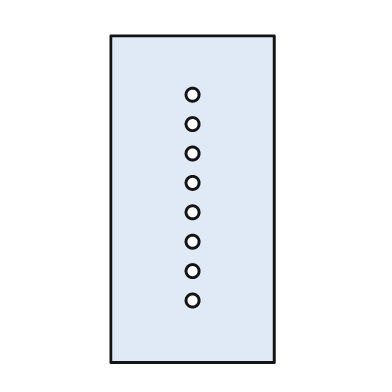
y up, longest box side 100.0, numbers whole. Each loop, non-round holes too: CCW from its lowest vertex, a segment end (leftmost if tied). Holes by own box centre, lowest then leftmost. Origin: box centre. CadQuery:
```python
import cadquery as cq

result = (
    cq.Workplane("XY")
    .moveTo(-25.0, -50.0)
    .lineTo(25.0, -50.0)
    .lineTo(25.0, 50.0)
    .lineTo(-25.0, 50.0)
    .close()
    .moveTo(0.0, -31.0)
    .circle(2.0)
    .moveTo(0.0, -22.0)
    .circle(2.0)
    .moveTo(0.0, -13.0)
    .circle(2.0)
    .moveTo(0.0, -4.0)
    .circle(2.0)
    .moveTo(0.0, 5.0)
    .circle(2.0)
    .moveTo(0.0, 14.0)
    .circle(2.0)
    .moveTo(0.0, 23.0)
    .circle(2.0)
    .moveTo(0.0, 32.0)
    .circle(2.0)
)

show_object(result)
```